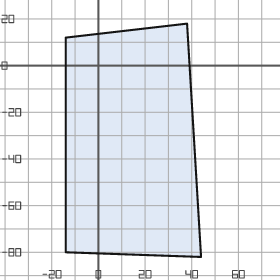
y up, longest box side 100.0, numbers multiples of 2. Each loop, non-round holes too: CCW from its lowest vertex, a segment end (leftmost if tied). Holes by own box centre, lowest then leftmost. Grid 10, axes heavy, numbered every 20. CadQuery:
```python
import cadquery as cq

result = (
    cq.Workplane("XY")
    .moveTo(44.0, -82.0)
    .lineTo(38.0, 18.0)
    .lineTo(-14.0, 12.0)
    .lineTo(-14.0, -80.0)
    .close()
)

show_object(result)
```